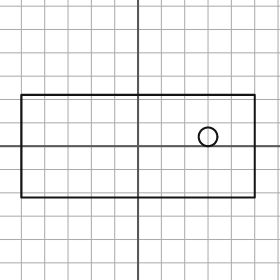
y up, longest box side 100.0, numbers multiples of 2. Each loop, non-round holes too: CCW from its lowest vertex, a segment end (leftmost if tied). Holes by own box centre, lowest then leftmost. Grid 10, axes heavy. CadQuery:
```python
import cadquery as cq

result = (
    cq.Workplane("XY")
    .moveTo(-50.0, -22.0)
    .lineTo(50.0, -22.0)
    .lineTo(50.0, 22.0)
    .lineTo(-50.0, 22.0)
    .close()
    .moveTo(30.0, 4.0)
    .circle(4.0)
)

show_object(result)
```